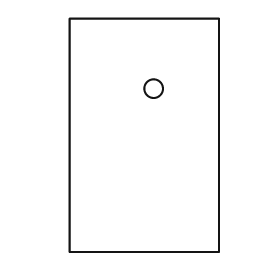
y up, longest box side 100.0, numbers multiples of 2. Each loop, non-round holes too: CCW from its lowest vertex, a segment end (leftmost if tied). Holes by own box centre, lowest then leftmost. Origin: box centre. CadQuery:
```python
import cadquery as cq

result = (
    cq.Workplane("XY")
    .moveTo(-32.0, -50.0)
    .lineTo(32.0, -50.0)
    .lineTo(32.0, 50.0)
    .lineTo(-32.0, 50.0)
    .close()
    .moveTo(4.0, 20.0)
    .circle(4.0)
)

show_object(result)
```